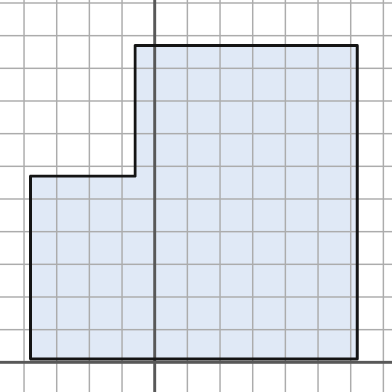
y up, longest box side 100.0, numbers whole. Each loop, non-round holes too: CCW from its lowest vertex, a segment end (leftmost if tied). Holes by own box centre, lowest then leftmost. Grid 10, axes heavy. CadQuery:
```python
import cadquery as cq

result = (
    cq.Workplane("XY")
    .moveTo(-38.0, 1.0)
    .lineTo(62.0, 1.0)
    .lineTo(62.0, 97.0)
    .lineTo(-6.0, 97.0)
    .lineTo(-6.0, 57.0)
    .lineTo(-38.0, 57.0)
    .close()
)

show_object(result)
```